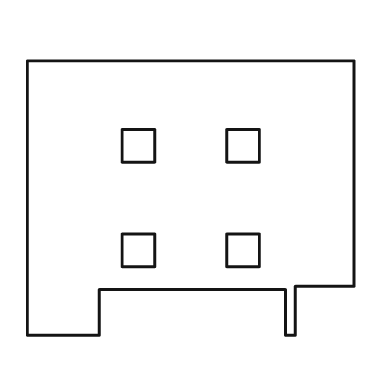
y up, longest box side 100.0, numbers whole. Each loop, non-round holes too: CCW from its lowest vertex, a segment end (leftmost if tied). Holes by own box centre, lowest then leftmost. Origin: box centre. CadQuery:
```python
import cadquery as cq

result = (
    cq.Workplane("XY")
    .moveTo(-50.0, -42.0)
    .lineTo(-28.0, -42.0)
    .lineTo(-28.0, -28.0)
    .lineTo(29.0, -28.0)
    .lineTo(29.0, -42.0)
    .lineTo(32.0, -42.0)
    .lineTo(32.0, -27.0)
    .lineTo(50.0, -27.0)
    .lineTo(50.0, 42.0)
    .lineTo(-50.0, 42.0)
    .close()
    .moveTo(-21.0, -21.0)
    .lineTo(-11.0, -21.0)
    .lineTo(-11.0, -11.0)
    .lineTo(-21.0, -11.0)
    .close()
    .moveTo(11.0, -21.0)
    .lineTo(21.0, -21.0)
    .lineTo(21.0, -11.0)
    .lineTo(11.0, -11.0)
    .close()
    .moveTo(-21.0, 11.0)
    .lineTo(-11.0, 11.0)
    .lineTo(-11.0, 21.0)
    .lineTo(-21.0, 21.0)
    .close()
    .moveTo(11.0, 11.0)
    .lineTo(21.0, 11.0)
    .lineTo(21.0, 21.0)
    .lineTo(11.0, 21.0)
    .close()
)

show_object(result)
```